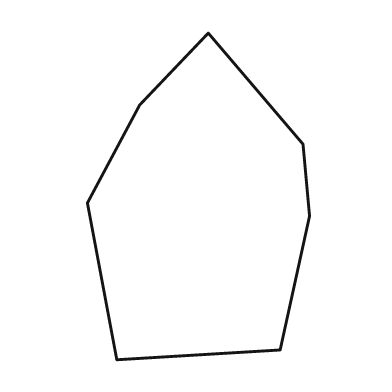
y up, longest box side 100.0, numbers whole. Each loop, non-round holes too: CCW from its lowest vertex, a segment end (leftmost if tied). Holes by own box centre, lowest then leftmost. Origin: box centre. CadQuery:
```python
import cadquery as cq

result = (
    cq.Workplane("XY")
    .moveTo(-25.0, -50.0)
    .lineTo(25.0, -47.0)
    .lineTo(34.0, -6.0)
    .lineTo(32.0, 16.0)
    .lineTo(3.0, 50.0)
    .lineTo(-18.0, 28.0)
    .lineTo(-34.0, -2.0)
    .close()
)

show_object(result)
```